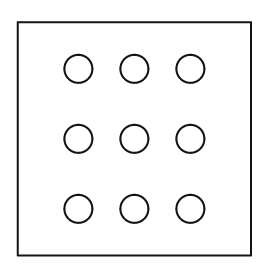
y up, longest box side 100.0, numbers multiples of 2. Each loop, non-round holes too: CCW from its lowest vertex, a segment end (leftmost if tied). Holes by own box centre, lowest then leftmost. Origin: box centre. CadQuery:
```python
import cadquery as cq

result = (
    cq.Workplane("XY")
    .moveTo(-50.0, -50.0)
    .lineTo(50.0, -50.0)
    .lineTo(50.0, 50.0)
    .lineTo(-50.0, 50.0)
    .close()
    .moveTo(-24.0, -30.0)
    .circle(6.0)
    .moveTo(0.0, -30.0)
    .circle(6.0)
    .moveTo(24.0, -30.0)
    .circle(6.0)
    .moveTo(-24.0, 0.0)
    .circle(6.0)
    .moveTo(0.0, 0.0)
    .circle(6.0)
    .moveTo(24.0, 0.0)
    .circle(6.0)
    .moveTo(-24.0, 30.0)
    .circle(6.0)
    .moveTo(0.0, 30.0)
    .circle(6.0)
    .moveTo(24.0, 30.0)
    .circle(6.0)
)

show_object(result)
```